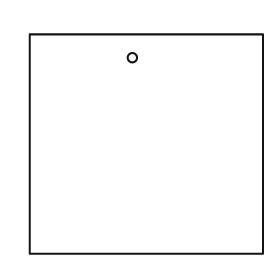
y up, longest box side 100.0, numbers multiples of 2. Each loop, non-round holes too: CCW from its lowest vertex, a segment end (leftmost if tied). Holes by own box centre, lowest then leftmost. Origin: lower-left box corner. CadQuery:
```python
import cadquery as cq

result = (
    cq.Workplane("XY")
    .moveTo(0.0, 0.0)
    .lineTo(100.0, 0.0)
    .lineTo(100.0, 94.0)
    .lineTo(0.0, 94.0)
    .close()
    .moveTo(44.0, 84.0)
    .circle(2.0)
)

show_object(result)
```